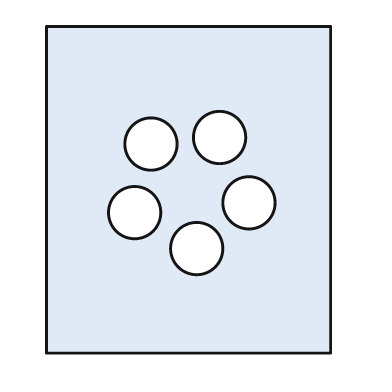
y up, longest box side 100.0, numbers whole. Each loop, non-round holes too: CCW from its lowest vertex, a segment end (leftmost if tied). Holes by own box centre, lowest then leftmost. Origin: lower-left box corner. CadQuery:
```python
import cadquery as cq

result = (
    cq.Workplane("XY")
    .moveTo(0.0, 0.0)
    .lineTo(87.0, 0.0)
    .lineTo(87.0, 100.0)
    .lineTo(0.0, 100.0)
    .close()
    .moveTo(46.0, 32.0)
    .circle(8.0)
    .moveTo(27.0, 43.0)
    .circle(8.0)
    .moveTo(62.0, 46.0)
    .circle(8.0)
    .moveTo(32.0, 64.0)
    .circle(8.0)
    .moveTo(53.0, 66.0)
    .circle(8.0)
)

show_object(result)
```